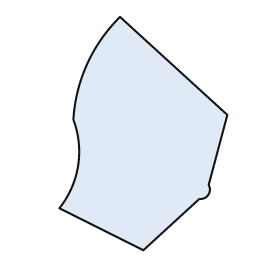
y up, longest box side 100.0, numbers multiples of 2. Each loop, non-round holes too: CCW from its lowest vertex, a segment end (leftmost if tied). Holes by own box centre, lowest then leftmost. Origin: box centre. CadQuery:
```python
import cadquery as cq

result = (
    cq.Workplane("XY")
    .moveTo(0.0, -50.0)
    .lineTo(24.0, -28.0)
    .threePointArc((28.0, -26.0), (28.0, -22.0))
    .lineTo(36.0, 8.0)
    .lineTo(-10.0, 50.0)
    .threePointArc((-24.0, 30.0), (-30.0, 6.0))
    .threePointArc((-28.0, -14.0), (-36.0, -32.0))
    .close()
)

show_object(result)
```